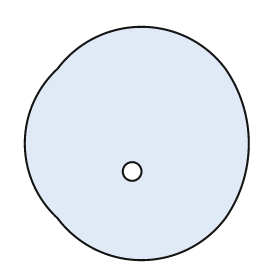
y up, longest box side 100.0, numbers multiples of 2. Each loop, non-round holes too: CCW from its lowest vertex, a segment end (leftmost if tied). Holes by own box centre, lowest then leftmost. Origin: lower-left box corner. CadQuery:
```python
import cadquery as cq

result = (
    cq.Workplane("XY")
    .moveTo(14.0, 18.0)
    .threePointArc((50.0, 0.0), (86.0, 18.0))
    .threePointArc((96.0, 50.0), (86.0, 82.0))
    .threePointArc((50.0, 100.0), (14.0, 82.0))
    .threePointArc((0.0, 50.0), (14.0, 18.0))
    .close()
    .moveTo(46.0, 38.0)
    .circle(4.0)
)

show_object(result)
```